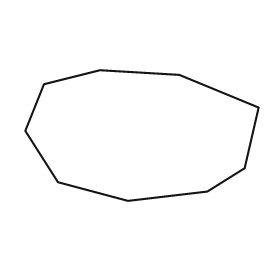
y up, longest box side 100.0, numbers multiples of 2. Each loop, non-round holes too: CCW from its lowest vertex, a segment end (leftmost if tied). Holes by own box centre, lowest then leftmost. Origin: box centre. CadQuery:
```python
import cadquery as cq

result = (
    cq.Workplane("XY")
    .moveTo(-6.0, -28.0)
    .lineTo(28.0, -24.0)
    .lineTo(44.0, -14.0)
    .lineTo(50.0, 12.0)
    .lineTo(16.0, 26.0)
    .lineTo(-18.0, 28.0)
    .lineTo(-42.0, 22.0)
    .lineTo(-50.0, 2.0)
    .lineTo(-36.0, -20.0)
    .close()
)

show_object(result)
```